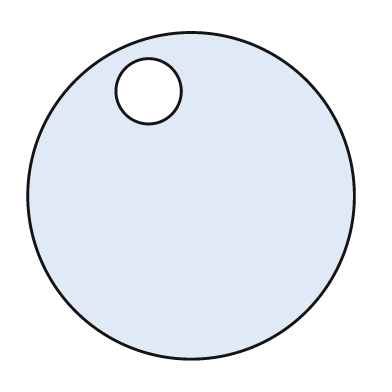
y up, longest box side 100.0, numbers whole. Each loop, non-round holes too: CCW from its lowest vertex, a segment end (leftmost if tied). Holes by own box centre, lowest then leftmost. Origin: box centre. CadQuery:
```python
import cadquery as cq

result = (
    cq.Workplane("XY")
    .moveTo(0.0, 0.0)
    .circle(50.0)
    .moveTo(-13.0, 32.0)
    .circle(10.0)
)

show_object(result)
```